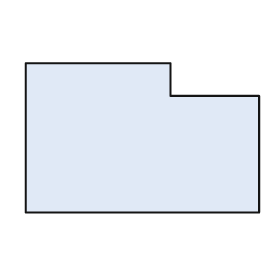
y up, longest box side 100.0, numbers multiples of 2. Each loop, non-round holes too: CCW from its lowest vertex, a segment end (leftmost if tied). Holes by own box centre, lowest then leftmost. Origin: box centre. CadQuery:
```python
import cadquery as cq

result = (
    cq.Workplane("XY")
    .moveTo(-50.0, -32.0)
    .lineTo(50.0, -32.0)
    .lineTo(50.0, 18.0)
    .lineTo(12.0, 18.0)
    .lineTo(12.0, 32.0)
    .lineTo(-50.0, 32.0)
    .close()
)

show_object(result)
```